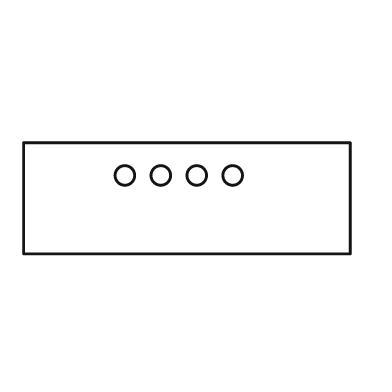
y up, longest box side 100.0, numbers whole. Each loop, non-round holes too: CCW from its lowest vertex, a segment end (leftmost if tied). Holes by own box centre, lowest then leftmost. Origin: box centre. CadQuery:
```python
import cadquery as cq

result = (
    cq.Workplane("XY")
    .moveTo(-50.0, -17.0)
    .lineTo(50.0, -17.0)
    .lineTo(50.0, 17.0)
    .lineTo(-50.0, 17.0)
    .close()
    .moveTo(-19.0, 7.0)
    .circle(3.0)
    .moveTo(-8.0, 7.0)
    .circle(3.0)
    .moveTo(3.0, 7.0)
    .circle(3.0)
    .moveTo(14.0, 7.0)
    .circle(3.0)
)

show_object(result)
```